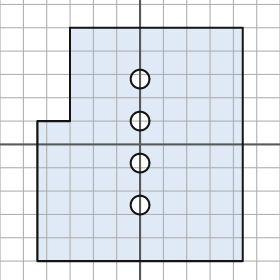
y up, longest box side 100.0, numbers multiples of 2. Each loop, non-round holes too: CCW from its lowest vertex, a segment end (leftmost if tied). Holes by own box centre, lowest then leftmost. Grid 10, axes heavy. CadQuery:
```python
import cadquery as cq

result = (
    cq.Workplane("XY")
    .moveTo(-44.0, -50.0)
    .lineTo(44.0, -50.0)
    .lineTo(44.0, 50.0)
    .lineTo(-30.0, 50.0)
    .lineTo(-30.0, 10.0)
    .lineTo(-44.0, 10.0)
    .close()
    .moveTo(0.0, -26.0)
    .circle(4.0)
    .moveTo(0.0, -8.0)
    .circle(4.0)
    .moveTo(0.0, 10.0)
    .circle(4.0)
    .moveTo(0.0, 28.0)
    .circle(4.0)
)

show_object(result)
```